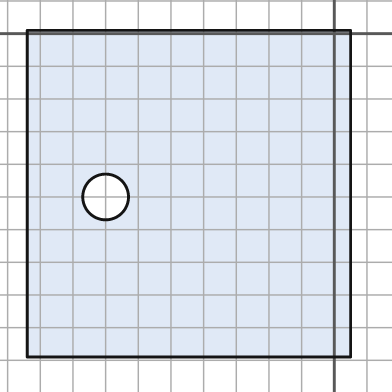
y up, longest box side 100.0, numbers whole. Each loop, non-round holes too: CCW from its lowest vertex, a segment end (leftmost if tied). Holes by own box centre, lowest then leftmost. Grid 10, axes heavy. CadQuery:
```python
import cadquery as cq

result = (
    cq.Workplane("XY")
    .moveTo(-94.0, -99.0)
    .lineTo(5.0, -99.0)
    .lineTo(5.0, 1.0)
    .lineTo(-94.0, 1.0)
    .close()
    .moveTo(-70.0, -50.0)
    .circle(7.0)
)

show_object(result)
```